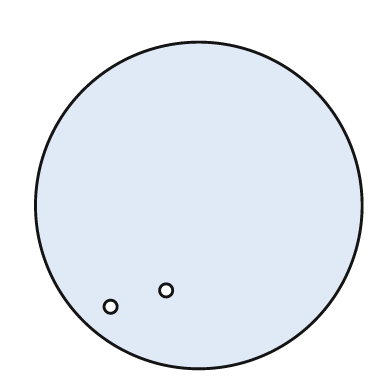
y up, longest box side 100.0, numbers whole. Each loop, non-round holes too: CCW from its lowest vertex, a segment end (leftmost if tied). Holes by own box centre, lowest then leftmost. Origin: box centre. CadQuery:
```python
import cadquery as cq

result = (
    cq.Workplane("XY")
    .moveTo(0.0, 0.0)
    .circle(50.0)
    .moveTo(-27.0, -31.0)
    .circle(2.0)
    .moveTo(-10.0, -26.0)
    .circle(2.0)
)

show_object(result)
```